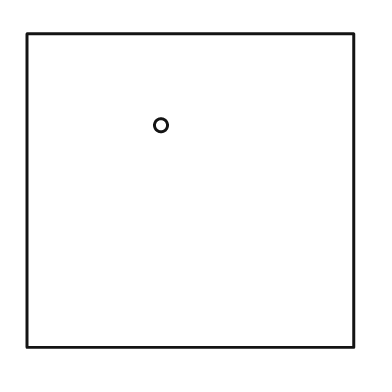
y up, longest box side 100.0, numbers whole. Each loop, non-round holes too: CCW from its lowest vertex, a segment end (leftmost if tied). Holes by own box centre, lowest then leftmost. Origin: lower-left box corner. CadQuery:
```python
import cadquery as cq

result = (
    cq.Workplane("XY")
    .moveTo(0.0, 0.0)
    .lineTo(100.0, 0.0)
    .lineTo(100.0, 96.0)
    .lineTo(0.0, 96.0)
    .close()
    .moveTo(41.0, 68.0)
    .circle(2.0)
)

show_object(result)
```